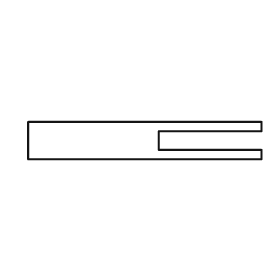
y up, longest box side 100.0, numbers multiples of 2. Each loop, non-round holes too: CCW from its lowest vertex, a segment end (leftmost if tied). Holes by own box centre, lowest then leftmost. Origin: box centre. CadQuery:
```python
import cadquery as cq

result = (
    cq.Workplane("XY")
    .moveTo(-50.0, -8.0)
    .lineTo(50.0, -8.0)
    .lineTo(50.0, -4.0)
    .lineTo(6.0, -4.0)
    .lineTo(6.0, 4.0)
    .lineTo(50.0, 4.0)
    .lineTo(50.0, 8.0)
    .lineTo(-50.0, 8.0)
    .close()
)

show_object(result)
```